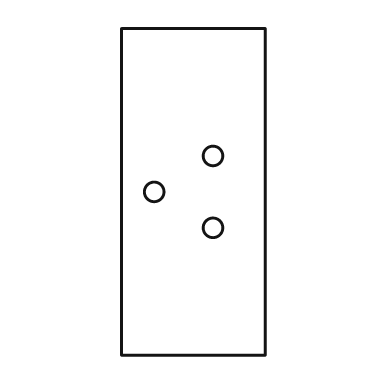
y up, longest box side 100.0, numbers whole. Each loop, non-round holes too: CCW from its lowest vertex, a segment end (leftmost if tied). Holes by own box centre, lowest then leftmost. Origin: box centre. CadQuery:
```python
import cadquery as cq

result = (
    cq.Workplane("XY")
    .moveTo(-22.0, -50.0)
    .lineTo(22.0, -50.0)
    .lineTo(22.0, 50.0)
    .lineTo(-22.0, 50.0)
    .close()
    .moveTo(6.0, -11.0)
    .circle(3.0)
    .moveTo(-12.0, 0.0)
    .circle(3.0)
    .moveTo(6.0, 11.0)
    .circle(3.0)
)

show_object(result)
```